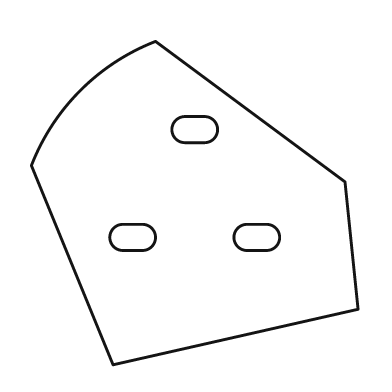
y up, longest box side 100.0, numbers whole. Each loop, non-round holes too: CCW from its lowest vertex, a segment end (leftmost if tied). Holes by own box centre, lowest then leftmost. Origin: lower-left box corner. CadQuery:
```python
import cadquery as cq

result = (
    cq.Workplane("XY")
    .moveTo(25.0, 0.0)
    .lineTo(100.0, 17.0)
    .lineTo(96.0, 56.0)
    .lineTo(38.0, 99.0)
    .threePointArc((15.0, 84.0), (0.0, 61.0))
    .close()
    .moveTo(28.0, 35.0)
    .lineTo(34.0, 35.0)
    .threePointArc((38.0, 39.0), (34.0, 43.0))
    .lineTo(28.0, 43.0)
    .threePointArc((24.0, 39.0), (28.0, 35.0))
    .close()
    .moveTo(66.0, 35.0)
    .lineTo(72.0, 35.0)
    .threePointArc((76.0, 39.0), (72.0, 43.0))
    .lineTo(66.0, 43.0)
    .threePointArc((62.0, 39.0), (66.0, 35.0))
    .close()
    .moveTo(47.0, 68.0)
    .lineTo(53.0, 68.0)
    .threePointArc((57.0, 72.0), (53.0, 76.0))
    .lineTo(47.0, 76.0)
    .threePointArc((43.0, 72.0), (47.0, 68.0))
    .close()
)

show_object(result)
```